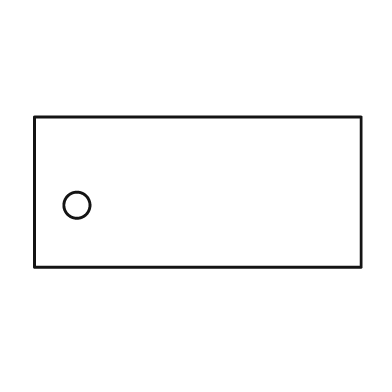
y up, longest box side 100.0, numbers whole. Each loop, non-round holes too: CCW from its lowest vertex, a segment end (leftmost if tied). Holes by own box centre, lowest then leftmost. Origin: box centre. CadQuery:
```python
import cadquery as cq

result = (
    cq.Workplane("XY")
    .moveTo(-50.0, -23.0)
    .lineTo(50.0, -23.0)
    .lineTo(50.0, 23.0)
    .lineTo(-50.0, 23.0)
    .close()
    .moveTo(-37.0, -4.0)
    .circle(4.0)
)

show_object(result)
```